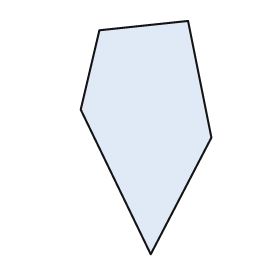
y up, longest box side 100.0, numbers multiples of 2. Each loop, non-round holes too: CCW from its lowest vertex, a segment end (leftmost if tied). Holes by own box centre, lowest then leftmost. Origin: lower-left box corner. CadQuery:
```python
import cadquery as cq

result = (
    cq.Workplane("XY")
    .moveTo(30.0, 0.0)
    .lineTo(56.0, 50.0)
    .lineTo(46.0, 100.0)
    .lineTo(8.0, 96.0)
    .lineTo(0.0, 62.0)
    .close()
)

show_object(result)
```